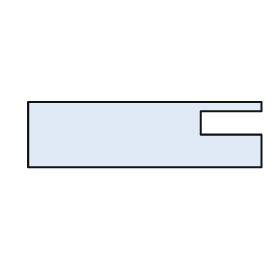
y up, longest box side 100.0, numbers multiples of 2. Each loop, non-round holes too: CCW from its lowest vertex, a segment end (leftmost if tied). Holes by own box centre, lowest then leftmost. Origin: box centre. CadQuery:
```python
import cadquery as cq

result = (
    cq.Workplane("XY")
    .moveTo(-50.0, -14.0)
    .lineTo(50.0, -14.0)
    .lineTo(50.0, 0.0)
    .lineTo(24.0, 0.0)
    .lineTo(24.0, 10.0)
    .lineTo(50.0, 10.0)
    .lineTo(50.0, 14.0)
    .lineTo(-50.0, 14.0)
    .close()
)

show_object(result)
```